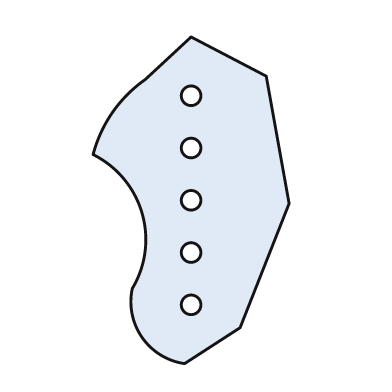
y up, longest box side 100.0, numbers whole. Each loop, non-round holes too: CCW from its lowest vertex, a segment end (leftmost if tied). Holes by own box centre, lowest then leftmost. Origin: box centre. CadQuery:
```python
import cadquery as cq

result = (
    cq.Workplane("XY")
    .moveTo(-2.0, -50.0)
    .lineTo(15.0, -39.0)
    .lineTo(30.0, -1.0)
    .lineTo(23.0, 38.0)
    .lineTo(0.0, 50.0)
    .lineTo(-14.0, 37.0)
    .threePointArc((-24.0, 27.0), (-30.0, 14.0))
    .threePointArc((-15.0, -4.0), (-18.0, -27.0))
    .threePointArc((-15.0, -42.0), (-2.0, -50.0))
    .close()
    .moveTo(0.0, -32.0)
    .circle(3.0)
    .moveTo(0.0, -16.0)
    .circle(3.0)
    .moveTo(0.0, 0.0)
    .circle(3.0)
    .moveTo(0.0, 16.0)
    .circle(3.0)
    .moveTo(0.0, 32.0)
    .circle(3.0)
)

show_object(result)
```